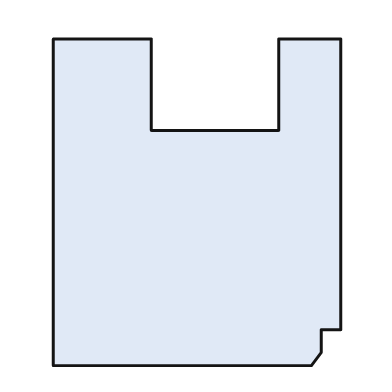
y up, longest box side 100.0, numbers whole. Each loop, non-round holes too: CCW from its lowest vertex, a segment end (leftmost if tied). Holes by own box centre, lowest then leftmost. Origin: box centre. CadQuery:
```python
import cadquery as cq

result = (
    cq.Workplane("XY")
    .moveTo(-44.0, -50.0)
    .lineTo(35.0, -50.0)
    .lineTo(38.0, -46.0)
    .lineTo(38.0, -39.0)
    .lineTo(44.0, -39.0)
    .lineTo(44.0, 50.0)
    .lineTo(25.0, 50.0)
    .lineTo(25.0, 22.0)
    .lineTo(-14.0, 22.0)
    .lineTo(-14.0, 50.0)
    .lineTo(-44.0, 50.0)
    .close()
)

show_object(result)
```